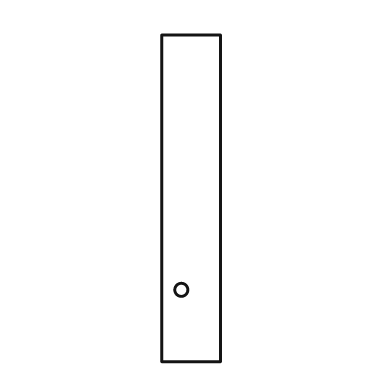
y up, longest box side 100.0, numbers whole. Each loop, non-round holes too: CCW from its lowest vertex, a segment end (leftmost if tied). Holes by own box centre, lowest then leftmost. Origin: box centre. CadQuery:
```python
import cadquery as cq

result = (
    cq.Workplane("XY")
    .moveTo(-9.0, -50.0)
    .lineTo(9.0, -50.0)
    .lineTo(9.0, 50.0)
    .lineTo(-9.0, 50.0)
    .close()
    .moveTo(-3.0, -28.0)
    .circle(2.0)
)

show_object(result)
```